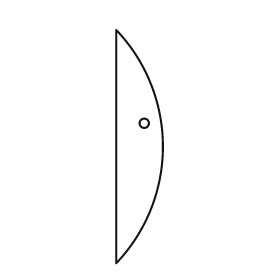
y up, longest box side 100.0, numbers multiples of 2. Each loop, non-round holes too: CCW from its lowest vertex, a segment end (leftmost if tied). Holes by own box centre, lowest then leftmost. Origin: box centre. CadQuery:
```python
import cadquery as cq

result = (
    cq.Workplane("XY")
    .moveTo(-10.0, -50.0)
    .threePointArc((10.0, 0.0), (-10.0, 50.0))
    .close()
    .moveTo(2.0, 10.0)
    .circle(2.0)
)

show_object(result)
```